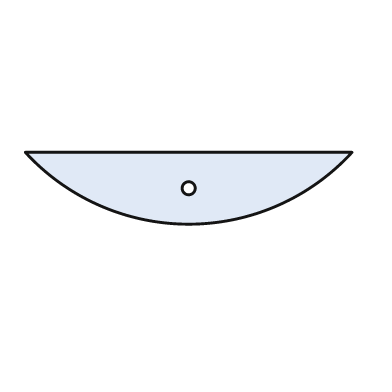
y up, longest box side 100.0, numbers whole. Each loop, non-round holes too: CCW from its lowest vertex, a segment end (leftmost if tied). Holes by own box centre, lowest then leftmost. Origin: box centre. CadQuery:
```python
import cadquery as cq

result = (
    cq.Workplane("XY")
    .moveTo(-50.0, 11.0)
    .threePointArc((0.0, -11.0), (50.0, 11.0))
    .close()
    .moveTo(0.0, 0.0)
    .circle(2.0)
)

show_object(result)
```